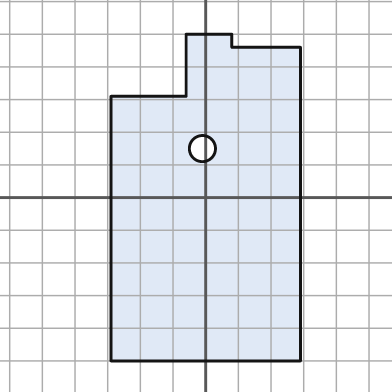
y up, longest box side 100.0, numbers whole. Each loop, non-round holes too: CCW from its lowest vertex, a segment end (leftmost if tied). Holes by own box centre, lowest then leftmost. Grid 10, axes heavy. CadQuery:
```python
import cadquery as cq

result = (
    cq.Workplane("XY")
    .moveTo(-29.0, -50.0)
    .lineTo(29.0, -50.0)
    .lineTo(29.0, 46.0)
    .lineTo(8.0, 46.0)
    .lineTo(8.0, 50.0)
    .lineTo(-6.0, 50.0)
    .lineTo(-6.0, 31.0)
    .lineTo(-29.0, 31.0)
    .close()
    .moveTo(-1.0, 15.0)
    .circle(4.0)
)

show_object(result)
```